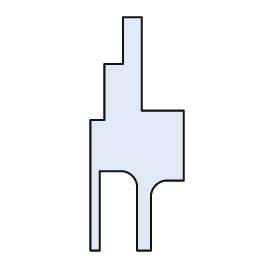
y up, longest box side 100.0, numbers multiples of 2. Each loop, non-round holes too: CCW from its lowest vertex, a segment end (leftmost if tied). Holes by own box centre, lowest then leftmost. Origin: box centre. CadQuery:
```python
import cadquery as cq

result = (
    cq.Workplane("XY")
    .moveTo(-20.0, -50.0)
    .lineTo(-16.0, -50.0)
    .lineTo(-16.0, -16.0)
    .lineTo(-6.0, -16.0)
    .threePointArc((-2.0, -18.0), (0.0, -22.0))
    .lineTo(0.0, -50.0)
    .lineTo(6.0, -50.0)
    .lineTo(6.0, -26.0)
    .threePointArc((8.0, -22.0), (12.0, -20.0))
    .lineTo(20.0, -20.0)
    .lineTo(20.0, 10.0)
    .lineTo(2.0, 10.0)
    .lineTo(2.0, 50.0)
    .lineTo(-6.0, 50.0)
    .lineTo(-6.0, 30.0)
    .lineTo(-14.0, 30.0)
    .lineTo(-14.0, 6.0)
    .lineTo(-20.0, 6.0)
    .close()
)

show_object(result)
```